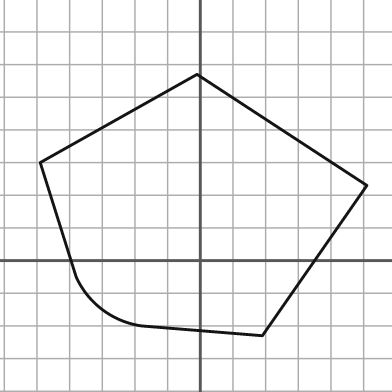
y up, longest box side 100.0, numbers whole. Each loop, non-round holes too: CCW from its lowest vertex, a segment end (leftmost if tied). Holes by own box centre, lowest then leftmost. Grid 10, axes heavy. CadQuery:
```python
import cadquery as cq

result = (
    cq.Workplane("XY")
    .moveTo(19.0, -23.0)
    .lineTo(51.0, 23.0)
    .lineTo(-1.0, 57.0)
    .lineTo(-49.0, 30.0)
    .lineTo(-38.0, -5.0)
    .threePointArc((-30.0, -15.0), (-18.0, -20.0))
    .close()
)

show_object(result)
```